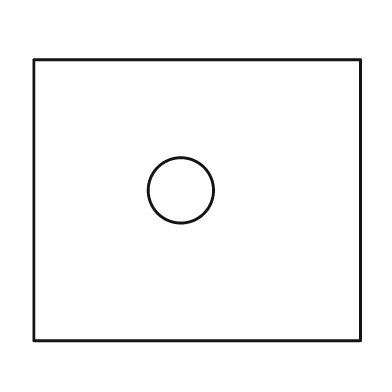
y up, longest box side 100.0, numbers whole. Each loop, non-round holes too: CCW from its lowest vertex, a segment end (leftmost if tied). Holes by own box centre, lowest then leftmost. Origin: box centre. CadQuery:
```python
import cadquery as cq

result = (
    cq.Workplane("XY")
    .moveTo(-50.0, -43.0)
    .lineTo(50.0, -43.0)
    .lineTo(50.0, 43.0)
    .lineTo(-50.0, 43.0)
    .close()
    .moveTo(-5.0, 3.0)
    .circle(10.0)
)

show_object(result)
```